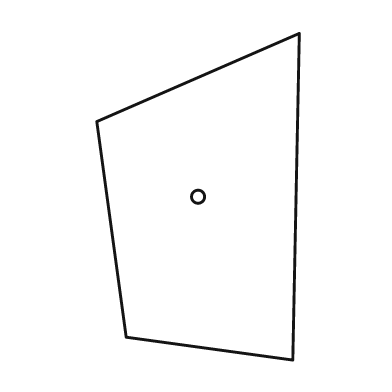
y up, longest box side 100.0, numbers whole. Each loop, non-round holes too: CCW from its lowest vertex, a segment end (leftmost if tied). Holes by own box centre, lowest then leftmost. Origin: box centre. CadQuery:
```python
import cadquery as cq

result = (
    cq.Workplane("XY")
    .moveTo(29.0, -50.0)
    .lineTo(31.0, 50.0)
    .lineTo(-31.0, 23.0)
    .lineTo(-22.0, -43.0)
    .close()
    .moveTo(0.0, 0.0)
    .circle(2.0)
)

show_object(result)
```